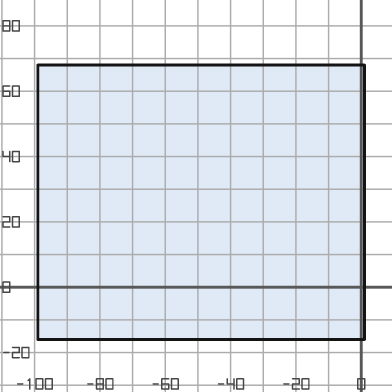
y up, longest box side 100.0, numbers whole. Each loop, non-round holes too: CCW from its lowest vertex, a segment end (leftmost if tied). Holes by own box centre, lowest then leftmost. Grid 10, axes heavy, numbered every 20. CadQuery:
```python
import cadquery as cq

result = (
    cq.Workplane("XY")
    .moveTo(-99.0, -16.0)
    .lineTo(1.0, -16.0)
    .lineTo(1.0, 68.0)
    .lineTo(-99.0, 68.0)
    .close()
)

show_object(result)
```